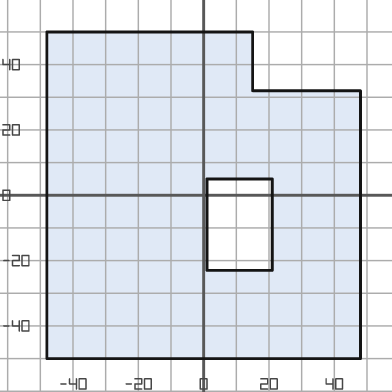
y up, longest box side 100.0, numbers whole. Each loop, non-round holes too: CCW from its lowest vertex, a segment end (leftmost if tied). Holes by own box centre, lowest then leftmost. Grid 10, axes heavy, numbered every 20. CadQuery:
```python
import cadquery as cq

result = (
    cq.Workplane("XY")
    .moveTo(-48.0, -50.0)
    .lineTo(48.0, -50.0)
    .lineTo(48.0, 32.0)
    .lineTo(15.0, 32.0)
    .lineTo(15.0, 50.0)
    .lineTo(-48.0, 50.0)
    .close()
    .moveTo(1.0, -23.0)
    .lineTo(21.0, -23.0)
    .lineTo(21.0, 5.0)
    .lineTo(1.0, 5.0)
    .close()
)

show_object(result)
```